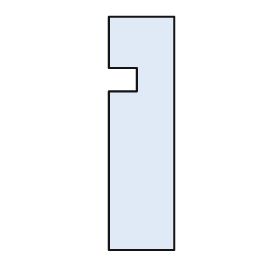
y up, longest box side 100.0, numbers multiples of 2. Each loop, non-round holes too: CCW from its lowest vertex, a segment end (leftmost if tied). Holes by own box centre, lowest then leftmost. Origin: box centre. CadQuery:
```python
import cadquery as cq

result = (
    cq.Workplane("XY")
    .moveTo(-14.0, -50.0)
    .lineTo(14.0, -50.0)
    .lineTo(14.0, 50.0)
    .lineTo(-14.0, 50.0)
    .lineTo(-14.0, 28.0)
    .lineTo(-2.0, 28.0)
    .lineTo(-2.0, 18.0)
    .lineTo(-14.0, 18.0)
    .close()
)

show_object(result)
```